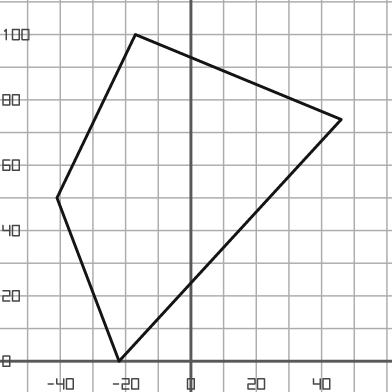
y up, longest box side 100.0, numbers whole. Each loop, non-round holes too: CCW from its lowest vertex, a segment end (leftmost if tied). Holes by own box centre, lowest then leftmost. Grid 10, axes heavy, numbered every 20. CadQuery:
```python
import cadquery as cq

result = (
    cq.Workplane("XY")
    .moveTo(-22.0, 0.0)
    .lineTo(46.0, 74.0)
    .lineTo(-17.0, 100.0)
    .lineTo(-41.0, 50.0)
    .close()
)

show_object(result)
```